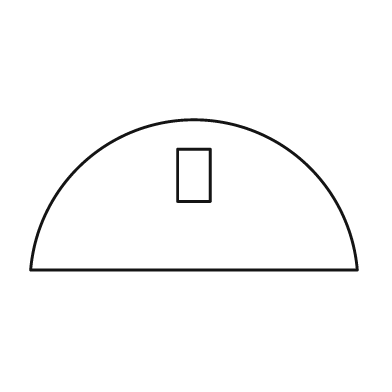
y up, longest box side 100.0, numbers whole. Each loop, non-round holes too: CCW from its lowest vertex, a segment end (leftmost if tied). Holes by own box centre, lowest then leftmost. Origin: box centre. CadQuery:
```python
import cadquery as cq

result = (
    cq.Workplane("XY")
    .moveTo(-50.0, -23.0)
    .lineTo(50.0, -23.0)
    .threePointArc((0.0, 23.0), (-50.0, -23.0))
    .close()
    .moveTo(-5.0, -2.0)
    .lineTo(5.0, -2.0)
    .lineTo(5.0, 14.0)
    .lineTo(-5.0, 14.0)
    .close()
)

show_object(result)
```